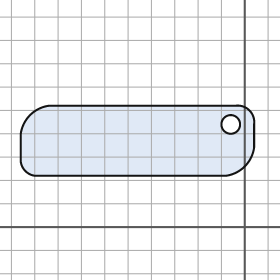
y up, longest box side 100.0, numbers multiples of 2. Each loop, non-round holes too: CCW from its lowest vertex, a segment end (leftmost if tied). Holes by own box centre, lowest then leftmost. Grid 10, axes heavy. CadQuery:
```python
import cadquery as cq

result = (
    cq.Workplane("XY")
    .moveTo(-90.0, 22.0)
    .lineTo(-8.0, 22.0)
    .threePointArc((0.0, 26.0), (4.0, 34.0))
    .lineTo(4.0, 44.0)
    .threePointArc((2.0, 50.0), (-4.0, 52.0))
    .lineTo(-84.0, 52.0)
    .threePointArc((-92.0, 48.0), (-96.0, 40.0))
    .lineTo(-96.0, 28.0)
    .threePointArc((-94.0, 24.0), (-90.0, 22.0))
    .close()
    .moveTo(-6.0, 44.0)
    .circle(4.0)
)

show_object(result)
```